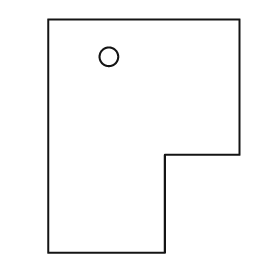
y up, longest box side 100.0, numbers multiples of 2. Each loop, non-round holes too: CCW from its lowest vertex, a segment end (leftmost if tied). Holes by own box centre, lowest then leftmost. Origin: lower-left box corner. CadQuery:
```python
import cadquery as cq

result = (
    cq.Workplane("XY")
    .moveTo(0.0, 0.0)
    .lineTo(50.0, 0.0)
    .lineTo(50.0, 42.0)
    .lineTo(82.0, 42.0)
    .lineTo(82.0, 100.0)
    .lineTo(0.0, 100.0)
    .close()
    .moveTo(26.0, 84.0)
    .circle(4.0)
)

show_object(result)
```